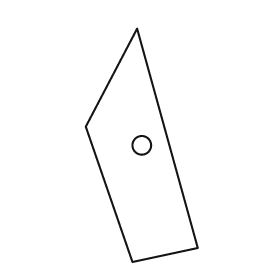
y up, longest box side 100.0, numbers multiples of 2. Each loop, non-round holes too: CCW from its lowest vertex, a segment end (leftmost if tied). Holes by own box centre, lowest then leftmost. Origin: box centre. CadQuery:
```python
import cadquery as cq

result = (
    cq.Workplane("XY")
    .moveTo(-4.0, -50.0)
    .lineTo(24.0, -44.0)
    .lineTo(-2.0, 50.0)
    .lineTo(-24.0, 8.0)
    .close()
    .moveTo(0.0, 0.0)
    .circle(4.0)
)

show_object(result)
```